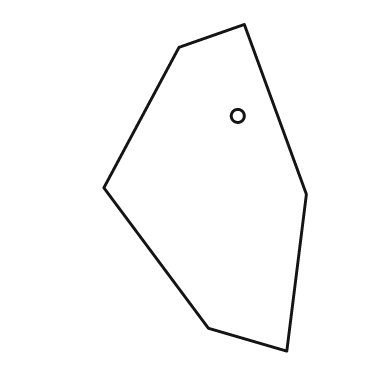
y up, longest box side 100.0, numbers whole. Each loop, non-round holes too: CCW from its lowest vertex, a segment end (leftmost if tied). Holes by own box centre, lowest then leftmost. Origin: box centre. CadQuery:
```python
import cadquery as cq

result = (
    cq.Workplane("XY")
    .moveTo(25.0, -50.0)
    .lineTo(31.0, -2.0)
    .lineTo(12.0, 50.0)
    .lineTo(-8.0, 43.0)
    .lineTo(-31.0, 0.0)
    .lineTo(1.0, -43.0)
    .close()
    .moveTo(10.0, 22.0)
    .circle(2.0)
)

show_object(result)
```